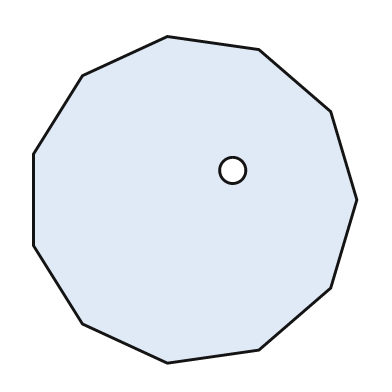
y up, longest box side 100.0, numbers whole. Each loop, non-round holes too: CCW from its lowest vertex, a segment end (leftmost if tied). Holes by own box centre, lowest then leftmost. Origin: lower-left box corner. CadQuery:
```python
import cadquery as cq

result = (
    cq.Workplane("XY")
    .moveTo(41.0, 0.0)
    .lineTo(69.0, 4.0)
    .lineTo(91.0, 23.0)
    .lineTo(99.0, 50.0)
    .lineTo(91.0, 77.0)
    .lineTo(69.0, 96.0)
    .lineTo(41.0, 100.0)
    .lineTo(15.0, 88.0)
    .lineTo(0.0, 64.0)
    .lineTo(0.0, 36.0)
    .lineTo(15.0, 12.0)
    .close()
    .moveTo(61.0, 59.0)
    .circle(4.0)
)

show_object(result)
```